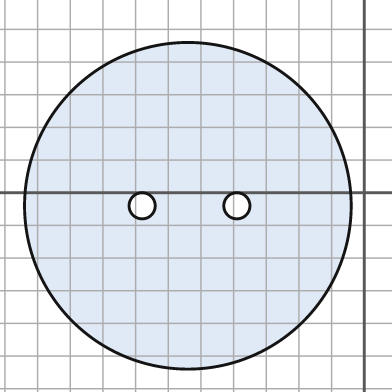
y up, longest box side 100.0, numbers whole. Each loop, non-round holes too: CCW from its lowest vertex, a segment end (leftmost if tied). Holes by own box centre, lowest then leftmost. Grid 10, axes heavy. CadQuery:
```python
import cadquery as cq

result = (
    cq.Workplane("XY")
    .moveTo(-54.0, -4.0)
    .circle(50.0)
    .moveTo(-68.0, -4.0)
    .circle(4.0)
    .moveTo(-39.0, -4.0)
    .circle(4.0)
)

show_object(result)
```